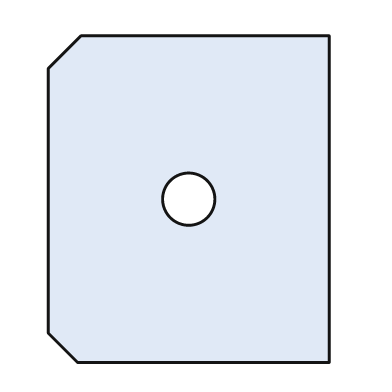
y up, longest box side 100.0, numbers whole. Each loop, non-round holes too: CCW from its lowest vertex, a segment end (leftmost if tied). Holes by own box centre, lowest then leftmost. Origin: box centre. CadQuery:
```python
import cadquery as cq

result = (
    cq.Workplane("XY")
    .moveTo(-34.0, -50.0)
    .lineTo(43.0, -50.0)
    .lineTo(43.0, 50.0)
    .lineTo(-33.0, 50.0)
    .lineTo(-43.0, 40.0)
    .lineTo(-43.0, -41.0)
    .close()
    .moveTo(0.0, 0.0)
    .circle(8.0)
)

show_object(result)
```